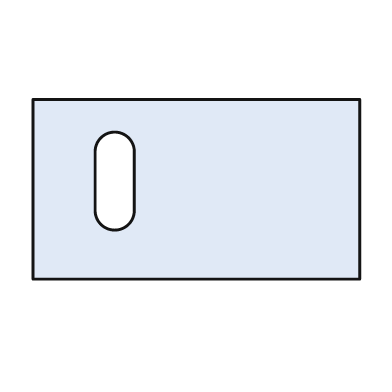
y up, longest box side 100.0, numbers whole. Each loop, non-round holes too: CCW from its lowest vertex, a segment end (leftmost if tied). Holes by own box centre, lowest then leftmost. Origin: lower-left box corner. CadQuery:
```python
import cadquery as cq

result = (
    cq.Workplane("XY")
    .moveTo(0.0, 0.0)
    .lineTo(100.0, 0.0)
    .lineTo(100.0, 55.0)
    .lineTo(0.0, 55.0)
    .close()
    .moveTo(19.0, 21.0)
    .threePointArc((25.0, 15.0), (31.0, 21.0))
    .lineTo(31.0, 39.0)
    .threePointArc((25.0, 45.0), (19.0, 39.0))
    .close()
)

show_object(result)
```